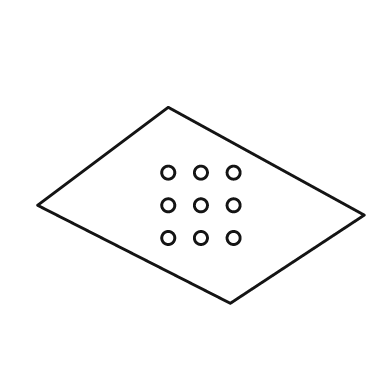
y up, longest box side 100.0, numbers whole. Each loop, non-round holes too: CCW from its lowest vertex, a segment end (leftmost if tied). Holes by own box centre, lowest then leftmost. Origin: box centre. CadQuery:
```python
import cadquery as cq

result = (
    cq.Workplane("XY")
    .moveTo(9.0, -30.0)
    .lineTo(50.0, -3.0)
    .lineTo(-10.0, 30.0)
    .lineTo(-50.0, 0.0)
    .close()
    .moveTo(-10.0, -10.0)
    .circle(2.0)
    .moveTo(0.0, -10.0)
    .circle(2.0)
    .moveTo(10.0, -10.0)
    .circle(2.0)
    .moveTo(-10.0, 0.0)
    .circle(2.0)
    .moveTo(0.0, 0.0)
    .circle(2.0)
    .moveTo(10.0, 0.0)
    .circle(2.0)
    .moveTo(-10.0, 10.0)
    .circle(2.0)
    .moveTo(0.0, 10.0)
    .circle(2.0)
    .moveTo(10.0, 10.0)
    .circle(2.0)
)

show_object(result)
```